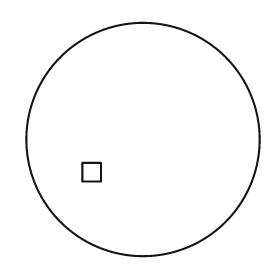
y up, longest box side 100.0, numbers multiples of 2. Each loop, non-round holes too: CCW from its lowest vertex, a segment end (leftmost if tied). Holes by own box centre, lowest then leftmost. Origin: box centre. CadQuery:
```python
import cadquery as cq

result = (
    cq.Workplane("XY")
    .moveTo(0.0, 0.0)
    .circle(50.0)
    .moveTo(-26.0, -18.0)
    .lineTo(-18.0, -18.0)
    .lineTo(-18.0, -10.0)
    .lineTo(-26.0, -10.0)
    .close()
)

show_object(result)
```